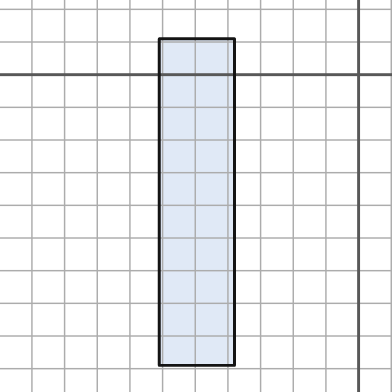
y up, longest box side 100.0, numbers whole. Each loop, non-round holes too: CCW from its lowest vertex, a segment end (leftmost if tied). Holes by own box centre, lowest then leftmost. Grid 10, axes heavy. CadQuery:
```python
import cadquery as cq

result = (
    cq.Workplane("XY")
    .moveTo(-61.0, -89.0)
    .lineTo(-38.0, -89.0)
    .lineTo(-38.0, 11.0)
    .lineTo(-61.0, 11.0)
    .close()
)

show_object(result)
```